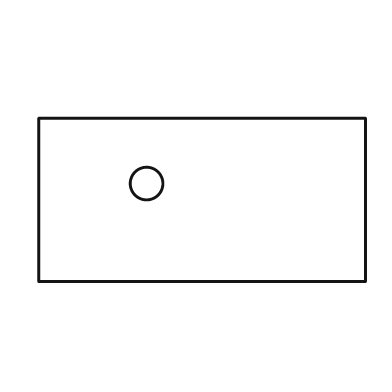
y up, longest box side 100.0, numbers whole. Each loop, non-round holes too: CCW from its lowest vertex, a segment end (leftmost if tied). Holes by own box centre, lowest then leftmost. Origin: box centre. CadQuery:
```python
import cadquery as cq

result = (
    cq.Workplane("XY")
    .moveTo(-50.0, -25.0)
    .lineTo(50.0, -25.0)
    .lineTo(50.0, 25.0)
    .lineTo(-50.0, 25.0)
    .close()
    .moveTo(-17.0, 5.0)
    .circle(5.0)
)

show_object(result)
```